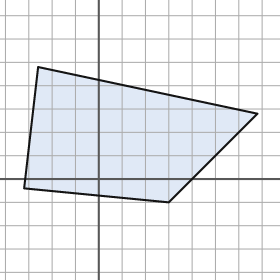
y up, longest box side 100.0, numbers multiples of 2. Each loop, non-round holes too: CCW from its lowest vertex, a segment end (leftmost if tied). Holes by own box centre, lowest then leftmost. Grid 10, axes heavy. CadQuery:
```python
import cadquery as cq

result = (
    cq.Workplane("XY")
    .moveTo(30.0, -10.0)
    .lineTo(68.0, 28.0)
    .lineTo(-26.0, 48.0)
    .lineTo(-32.0, -4.0)
    .close()
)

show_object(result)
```